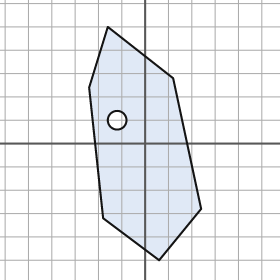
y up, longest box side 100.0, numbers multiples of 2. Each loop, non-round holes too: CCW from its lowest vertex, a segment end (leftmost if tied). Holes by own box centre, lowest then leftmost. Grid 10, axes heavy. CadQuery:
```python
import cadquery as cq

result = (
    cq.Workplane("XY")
    .moveTo(6.0, -50.0)
    .lineTo(24.0, -28.0)
    .lineTo(12.0, 28.0)
    .lineTo(-16.0, 50.0)
    .lineTo(-24.0, 24.0)
    .lineTo(-18.0, -32.0)
    .close()
    .moveTo(-12.0, 10.0)
    .circle(4.0)
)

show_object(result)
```